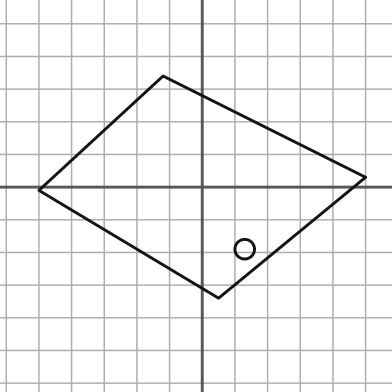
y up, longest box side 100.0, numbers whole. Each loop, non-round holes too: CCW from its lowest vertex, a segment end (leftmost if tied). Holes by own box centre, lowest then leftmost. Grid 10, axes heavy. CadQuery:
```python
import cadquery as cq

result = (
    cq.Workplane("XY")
    .moveTo(5.0, -34.0)
    .lineTo(50.0, 3.0)
    .lineTo(-12.0, 34.0)
    .lineTo(-50.0, -1.0)
    .close()
    .moveTo(13.0, -19.0)
    .circle(3.0)
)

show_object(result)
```